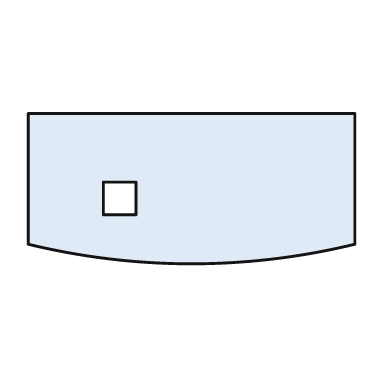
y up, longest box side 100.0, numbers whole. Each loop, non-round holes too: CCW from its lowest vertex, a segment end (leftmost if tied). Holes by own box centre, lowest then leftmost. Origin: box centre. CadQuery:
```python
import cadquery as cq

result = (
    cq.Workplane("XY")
    .moveTo(-50.0, -17.0)
    .threePointArc((0.0, -23.0), (50.0, -17.0))
    .lineTo(50.0, 23.0)
    .lineTo(-50.0, 23.0)
    .close()
    .moveTo(-27.0, -8.0)
    .lineTo(-17.0, -8.0)
    .lineTo(-17.0, 2.0)
    .lineTo(-27.0, 2.0)
    .close()
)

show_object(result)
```